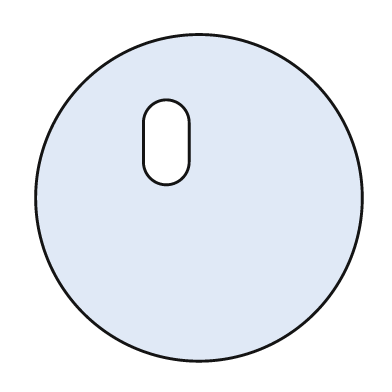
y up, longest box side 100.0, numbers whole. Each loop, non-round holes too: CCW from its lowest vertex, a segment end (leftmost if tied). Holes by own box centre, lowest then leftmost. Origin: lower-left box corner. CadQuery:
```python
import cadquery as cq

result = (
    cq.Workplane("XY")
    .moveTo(50.0, 50.0)
    .circle(50.0)
    .moveTo(33.0, 61.0)
    .threePointArc((40.0, 54.0), (47.0, 61.0))
    .lineTo(47.0, 73.0)
    .threePointArc((40.0, 80.0), (33.0, 73.0))
    .close()
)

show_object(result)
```